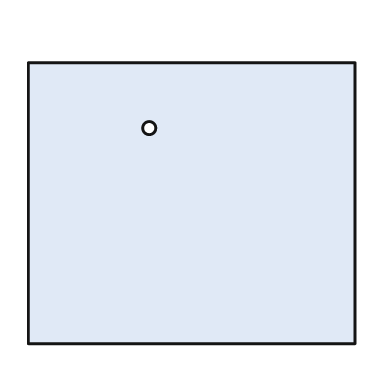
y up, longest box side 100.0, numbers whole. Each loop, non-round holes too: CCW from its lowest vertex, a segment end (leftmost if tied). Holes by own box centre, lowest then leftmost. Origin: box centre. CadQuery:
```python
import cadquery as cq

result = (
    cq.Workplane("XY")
    .moveTo(-50.0, -43.0)
    .lineTo(50.0, -43.0)
    .lineTo(50.0, 43.0)
    .lineTo(-50.0, 43.0)
    .close()
    .moveTo(-13.0, 23.0)
    .circle(2.0)
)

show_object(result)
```